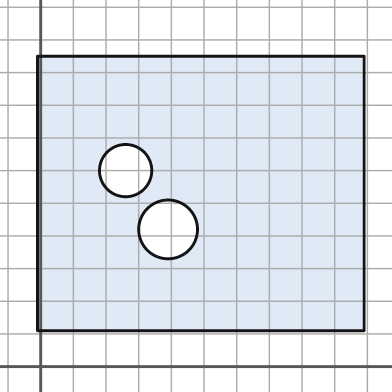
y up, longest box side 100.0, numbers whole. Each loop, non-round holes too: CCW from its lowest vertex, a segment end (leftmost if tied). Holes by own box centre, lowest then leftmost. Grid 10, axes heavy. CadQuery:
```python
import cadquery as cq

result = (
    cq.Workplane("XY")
    .moveTo(-1.0, 11.0)
    .lineTo(99.0, 11.0)
    .lineTo(99.0, 95.0)
    .lineTo(-1.0, 95.0)
    .close()
    .moveTo(39.0, 42.0)
    .circle(9.0)
    .moveTo(26.0, 60.0)
    .circle(8.0)
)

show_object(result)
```